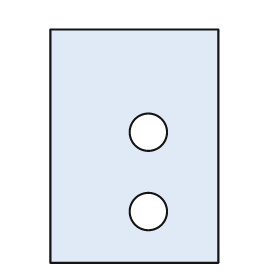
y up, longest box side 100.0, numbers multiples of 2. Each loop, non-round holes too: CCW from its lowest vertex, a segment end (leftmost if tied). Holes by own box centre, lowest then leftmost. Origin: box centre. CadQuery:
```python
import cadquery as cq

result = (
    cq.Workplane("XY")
    .moveTo(-36.0, -50.0)
    .lineTo(36.0, -50.0)
    .lineTo(36.0, 50.0)
    .lineTo(-36.0, 50.0)
    .close()
    .moveTo(6.0, -28.0)
    .circle(8.0)
    .moveTo(6.0, 6.0)
    .circle(8.0)
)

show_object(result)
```